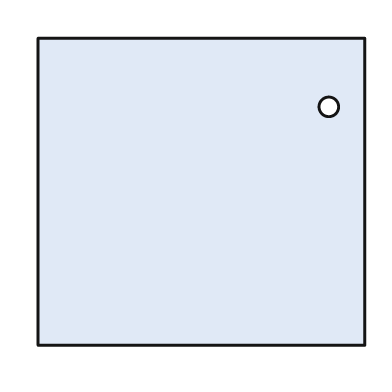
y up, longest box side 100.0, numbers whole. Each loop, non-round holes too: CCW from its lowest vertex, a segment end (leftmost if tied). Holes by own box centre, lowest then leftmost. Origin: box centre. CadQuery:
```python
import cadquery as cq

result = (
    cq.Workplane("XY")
    .moveTo(-50.0, -47.0)
    .lineTo(50.0, -47.0)
    .lineTo(50.0, 47.0)
    .lineTo(-50.0, 47.0)
    .close()
    .moveTo(39.0, 26.0)
    .circle(3.0)
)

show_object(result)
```